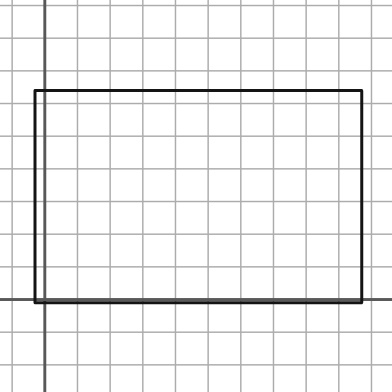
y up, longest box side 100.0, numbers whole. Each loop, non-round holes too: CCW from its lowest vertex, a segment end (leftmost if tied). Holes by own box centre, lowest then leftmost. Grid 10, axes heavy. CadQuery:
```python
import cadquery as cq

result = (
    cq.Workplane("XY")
    .moveTo(-3.0, -1.0)
    .lineTo(97.0, -1.0)
    .lineTo(97.0, 64.0)
    .lineTo(-3.0, 64.0)
    .close()
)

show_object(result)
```